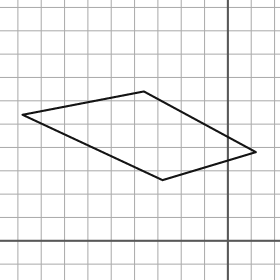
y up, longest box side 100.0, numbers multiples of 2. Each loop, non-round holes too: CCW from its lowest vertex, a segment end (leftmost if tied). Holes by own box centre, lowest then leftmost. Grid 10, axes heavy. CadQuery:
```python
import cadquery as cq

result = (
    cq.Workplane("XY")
    .moveTo(-28.0, 26.0)
    .lineTo(12.0, 38.0)
    .lineTo(-36.0, 64.0)
    .lineTo(-88.0, 54.0)
    .close()
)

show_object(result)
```